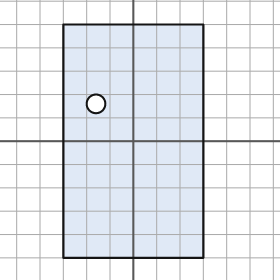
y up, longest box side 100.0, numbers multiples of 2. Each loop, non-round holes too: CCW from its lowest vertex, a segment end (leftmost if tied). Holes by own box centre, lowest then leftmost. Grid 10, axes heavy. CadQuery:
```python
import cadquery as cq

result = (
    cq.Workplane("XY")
    .moveTo(-30.0, -50.0)
    .lineTo(30.0, -50.0)
    .lineTo(30.0, 50.0)
    .lineTo(-30.0, 50.0)
    .close()
    .moveTo(-16.0, 16.0)
    .circle(4.0)
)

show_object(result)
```